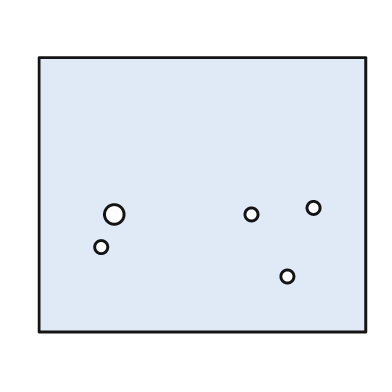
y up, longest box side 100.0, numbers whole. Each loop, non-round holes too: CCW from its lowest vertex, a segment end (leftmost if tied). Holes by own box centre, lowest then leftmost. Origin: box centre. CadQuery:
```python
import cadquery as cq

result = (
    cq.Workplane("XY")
    .moveTo(-50.0, -42.0)
    .lineTo(50.0, -42.0)
    .lineTo(50.0, 42.0)
    .lineTo(-50.0, 42.0)
    .close()
    .moveTo(26.0, -25.0)
    .circle(2.0)
    .moveTo(-31.0, -16.0)
    .circle(2.0)
    .moveTo(-27.0, -6.0)
    .circle(3.0)
    .moveTo(15.0, -6.0)
    .circle(2.0)
    .moveTo(34.0, -4.0)
    .circle(2.0)
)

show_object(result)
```